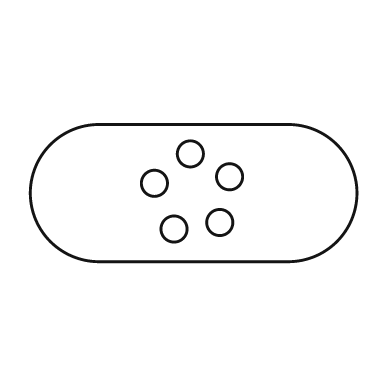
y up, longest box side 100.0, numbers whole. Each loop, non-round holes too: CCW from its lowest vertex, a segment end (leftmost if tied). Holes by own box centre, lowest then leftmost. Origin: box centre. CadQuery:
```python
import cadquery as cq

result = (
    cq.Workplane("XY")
    .moveTo(-29.0, -21.0)
    .lineTo(29.0, -21.0)
    .threePointArc((50.0, 0.0), (29.0, 21.0))
    .lineTo(-29.0, 21.0)
    .threePointArc((-50.0, 0.0), (-29.0, -21.0))
    .close()
    .moveTo(-6.0, -11.0)
    .circle(4.0)
    .moveTo(8.0, -9.0)
    .circle(4.0)
    .moveTo(-12.0, 3.0)
    .circle(4.0)
    .moveTo(11.0, 5.0)
    .circle(4.0)
    .moveTo(-1.0, 12.0)
    .circle(4.0)
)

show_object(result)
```